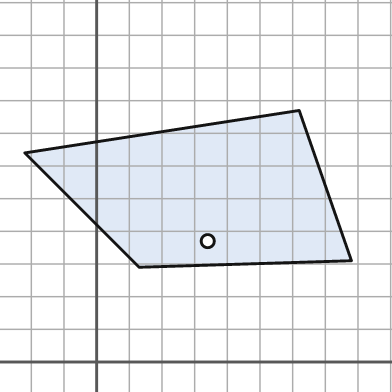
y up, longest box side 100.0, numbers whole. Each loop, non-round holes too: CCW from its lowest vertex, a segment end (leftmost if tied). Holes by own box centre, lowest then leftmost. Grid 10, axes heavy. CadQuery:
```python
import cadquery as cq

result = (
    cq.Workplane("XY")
    .moveTo(13.0, 29.0)
    .lineTo(78.0, 31.0)
    .lineTo(62.0, 77.0)
    .lineTo(-22.0, 64.0)
    .close()
    .moveTo(34.0, 37.0)
    .circle(2.0)
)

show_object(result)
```